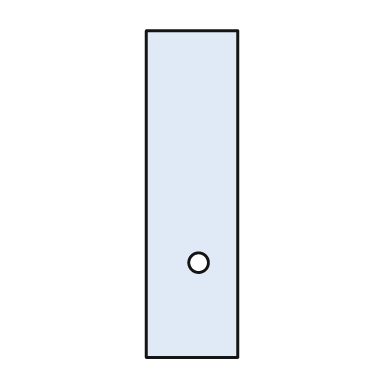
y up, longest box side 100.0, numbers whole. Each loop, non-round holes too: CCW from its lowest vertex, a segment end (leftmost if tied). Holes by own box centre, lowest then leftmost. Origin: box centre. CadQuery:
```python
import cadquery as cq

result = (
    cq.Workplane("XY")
    .moveTo(-14.0, -50.0)
    .lineTo(14.0, -50.0)
    .lineTo(14.0, 50.0)
    .lineTo(-14.0, 50.0)
    .close()
    .moveTo(2.0, -21.0)
    .circle(3.0)
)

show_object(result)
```